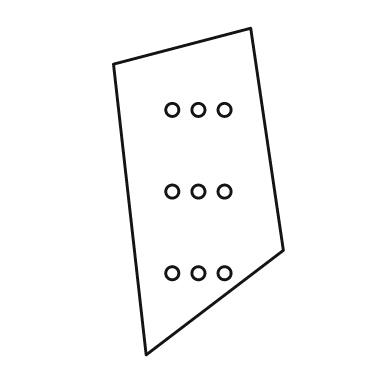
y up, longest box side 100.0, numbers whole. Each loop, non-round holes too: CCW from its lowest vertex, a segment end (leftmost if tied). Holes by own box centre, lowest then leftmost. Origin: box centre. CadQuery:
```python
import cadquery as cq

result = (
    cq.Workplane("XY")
    .moveTo(-16.0, -50.0)
    .lineTo(26.0, -18.0)
    .lineTo(16.0, 50.0)
    .lineTo(-26.0, 39.0)
    .close()
    .moveTo(-8.0, -25.0)
    .circle(2.0)
    .moveTo(0.0, -25.0)
    .circle(2.0)
    .moveTo(8.0, -25.0)
    .circle(2.0)
    .moveTo(-8.0, 0.0)
    .circle(2.0)
    .moveTo(0.0, 0.0)
    .circle(2.0)
    .moveTo(8.0, 0.0)
    .circle(2.0)
    .moveTo(-8.0, 25.0)
    .circle(2.0)
    .moveTo(0.0, 25.0)
    .circle(2.0)
    .moveTo(8.0, 25.0)
    .circle(2.0)
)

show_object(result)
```